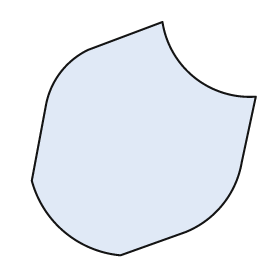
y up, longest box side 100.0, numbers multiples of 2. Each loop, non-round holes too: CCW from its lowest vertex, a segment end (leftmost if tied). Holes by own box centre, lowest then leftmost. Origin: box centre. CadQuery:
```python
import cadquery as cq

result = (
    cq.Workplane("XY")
    .moveTo(-10.0, -50.0)
    .lineTo(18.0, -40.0)
    .threePointArc((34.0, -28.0), (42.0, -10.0))
    .lineTo(48.0, 18.0)
    .threePointArc((22.0, 26.0), (8.0, 50.0))
    .lineTo(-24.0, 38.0)
    .threePointArc((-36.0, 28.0), (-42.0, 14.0))
    .lineTo(-48.0, -18.0)
    .threePointArc((-34.0, -40.0), (-10.0, -50.0))
    .close()
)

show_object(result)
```